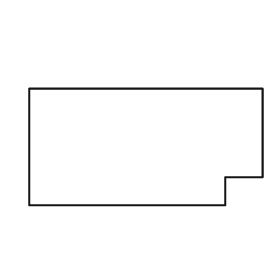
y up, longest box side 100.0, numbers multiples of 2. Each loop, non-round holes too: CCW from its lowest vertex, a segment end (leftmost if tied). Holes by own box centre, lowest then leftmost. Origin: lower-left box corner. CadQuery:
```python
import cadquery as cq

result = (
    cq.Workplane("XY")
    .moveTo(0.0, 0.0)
    .lineTo(84.0, 0.0)
    .lineTo(84.0, 12.0)
    .lineTo(100.0, 12.0)
    .lineTo(100.0, 50.0)
    .lineTo(0.0, 50.0)
    .close()
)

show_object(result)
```